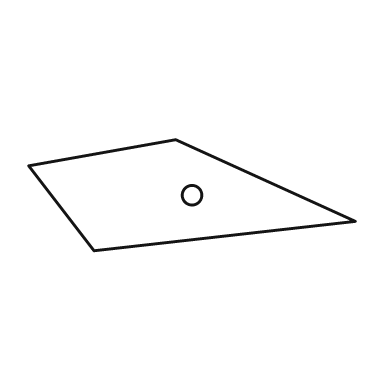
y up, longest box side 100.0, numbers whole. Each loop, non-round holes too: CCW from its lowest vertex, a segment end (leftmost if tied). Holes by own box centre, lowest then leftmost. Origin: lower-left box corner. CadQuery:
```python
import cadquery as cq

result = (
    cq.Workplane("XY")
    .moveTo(20.0, 0.0)
    .lineTo(100.0, 9.0)
    .lineTo(45.0, 34.0)
    .lineTo(0.0, 26.0)
    .close()
    .moveTo(50.0, 17.0)
    .circle(3.0)
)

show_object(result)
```